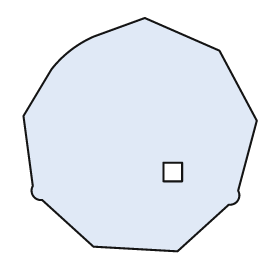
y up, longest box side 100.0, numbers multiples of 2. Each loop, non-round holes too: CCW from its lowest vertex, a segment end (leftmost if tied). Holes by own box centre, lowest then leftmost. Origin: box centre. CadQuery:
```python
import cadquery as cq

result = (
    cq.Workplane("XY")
    .moveTo(16.0, -50.0)
    .lineTo(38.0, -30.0)
    .threePointArc((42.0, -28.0), (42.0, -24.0))
    .lineTo(50.0, 6.0)
    .lineTo(34.0, 36.0)
    .lineTo(2.0, 50.0)
    .lineTo(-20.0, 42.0)
    .threePointArc((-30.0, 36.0), (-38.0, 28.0))
    .lineTo(-50.0, 8.0)
    .lineTo(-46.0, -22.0)
    .threePointArc((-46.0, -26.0), (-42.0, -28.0))
    .lineTo(-20.0, -48.0)
    .close()
    .moveTo(10.0, -20.0)
    .lineTo(18.0, -20.0)
    .lineTo(18.0, -12.0)
    .lineTo(10.0, -12.0)
    .close()
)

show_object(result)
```